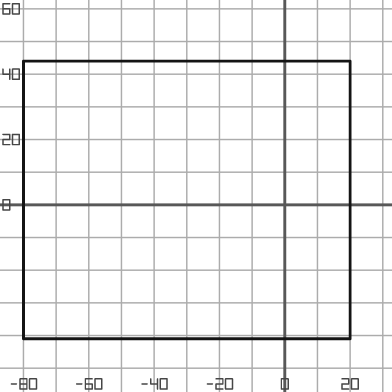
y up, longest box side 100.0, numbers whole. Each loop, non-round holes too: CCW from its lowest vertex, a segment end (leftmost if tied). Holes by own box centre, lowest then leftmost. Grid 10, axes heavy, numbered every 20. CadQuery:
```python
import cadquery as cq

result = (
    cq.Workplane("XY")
    .moveTo(-80.0, -41.0)
    .lineTo(20.0, -41.0)
    .lineTo(20.0, 44.0)
    .lineTo(-80.0, 44.0)
    .close()
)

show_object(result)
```